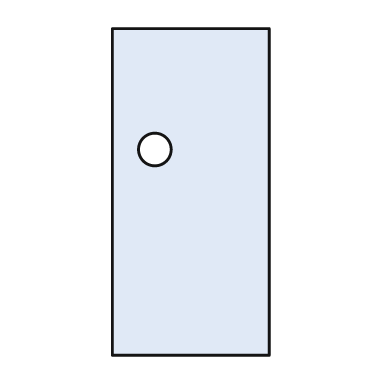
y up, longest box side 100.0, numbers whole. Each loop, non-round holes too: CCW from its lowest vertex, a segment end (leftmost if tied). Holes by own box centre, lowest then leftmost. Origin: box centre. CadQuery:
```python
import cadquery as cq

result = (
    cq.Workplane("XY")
    .moveTo(-24.0, -50.0)
    .lineTo(24.0, -50.0)
    .lineTo(24.0, 50.0)
    .lineTo(-24.0, 50.0)
    .close()
    .moveTo(-11.0, 13.0)
    .circle(5.0)
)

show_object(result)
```